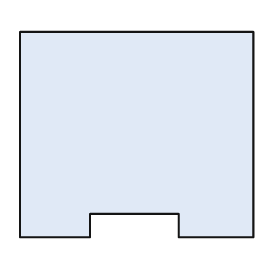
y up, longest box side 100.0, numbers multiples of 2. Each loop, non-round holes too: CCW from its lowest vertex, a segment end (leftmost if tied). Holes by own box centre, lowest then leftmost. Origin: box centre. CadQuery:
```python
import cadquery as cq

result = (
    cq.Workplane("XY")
    .moveTo(-50.0, -44.0)
    .lineTo(-20.0, -44.0)
    .lineTo(-20.0, -34.0)
    .lineTo(18.0, -34.0)
    .lineTo(18.0, -44.0)
    .lineTo(50.0, -44.0)
    .lineTo(50.0, 44.0)
    .lineTo(-50.0, 44.0)
    .close()
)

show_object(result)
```